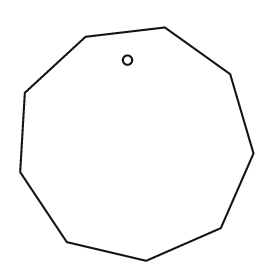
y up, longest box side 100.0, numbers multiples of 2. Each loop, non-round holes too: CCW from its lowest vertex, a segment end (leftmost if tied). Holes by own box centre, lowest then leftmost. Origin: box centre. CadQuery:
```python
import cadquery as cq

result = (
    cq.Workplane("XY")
    .moveTo(4.0, -50.0)
    .lineTo(36.0, -36.0)
    .lineTo(50.0, -4.0)
    .lineTo(40.0, 30.0)
    .lineTo(12.0, 50.0)
    .lineTo(-22.0, 46.0)
    .lineTo(-48.0, 22.0)
    .lineTo(-50.0, -12.0)
    .lineTo(-30.0, -42.0)
    .close()
    .moveTo(-4.0, 36.0)
    .circle(2.0)
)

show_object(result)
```